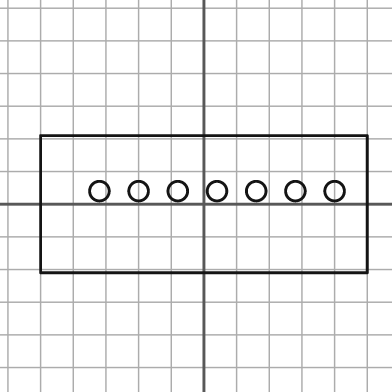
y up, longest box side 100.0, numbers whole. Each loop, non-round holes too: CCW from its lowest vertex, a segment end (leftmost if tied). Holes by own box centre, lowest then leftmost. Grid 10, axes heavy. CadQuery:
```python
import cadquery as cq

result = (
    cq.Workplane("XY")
    .moveTo(-50.0, -21.0)
    .lineTo(50.0, -21.0)
    .lineTo(50.0, 21.0)
    .lineTo(-50.0, 21.0)
    .close()
    .moveTo(-32.0, 4.0)
    .circle(3.0)
    .moveTo(-20.0, 4.0)
    .circle(3.0)
    .moveTo(-8.0, 4.0)
    .circle(3.0)
    .moveTo(4.0, 4.0)
    .circle(3.0)
    .moveTo(16.0, 4.0)
    .circle(3.0)
    .moveTo(28.0, 4.0)
    .circle(3.0)
    .moveTo(40.0, 4.0)
    .circle(3.0)
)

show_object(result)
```